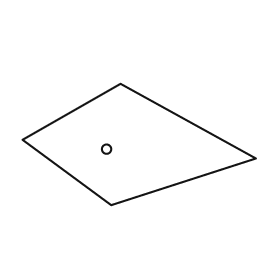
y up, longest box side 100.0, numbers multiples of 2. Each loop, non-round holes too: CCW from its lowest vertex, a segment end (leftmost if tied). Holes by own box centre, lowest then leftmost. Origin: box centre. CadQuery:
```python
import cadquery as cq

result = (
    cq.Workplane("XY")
    .moveTo(-12.0, -26.0)
    .lineTo(50.0, -6.0)
    .lineTo(-8.0, 26.0)
    .lineTo(-50.0, 2.0)
    .close()
    .moveTo(-14.0, -2.0)
    .circle(2.0)
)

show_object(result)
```